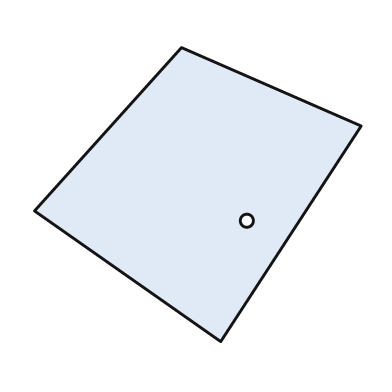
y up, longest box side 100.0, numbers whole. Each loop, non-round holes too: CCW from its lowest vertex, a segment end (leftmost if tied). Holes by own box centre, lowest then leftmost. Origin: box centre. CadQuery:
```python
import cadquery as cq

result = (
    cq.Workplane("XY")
    .moveTo(7.0, -45.0)
    .lineTo(50.0, 21.0)
    .lineTo(-5.0, 45.0)
    .lineTo(-50.0, -5.0)
    .close()
    .moveTo(15.0, -8.0)
    .circle(2.0)
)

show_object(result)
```